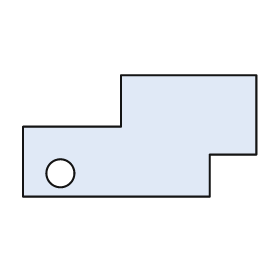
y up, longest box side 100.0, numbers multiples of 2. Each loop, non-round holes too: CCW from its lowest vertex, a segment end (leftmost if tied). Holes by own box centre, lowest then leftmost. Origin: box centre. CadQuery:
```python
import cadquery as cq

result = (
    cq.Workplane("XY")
    .moveTo(-50.0, -26.0)
    .lineTo(30.0, -26.0)
    .lineTo(30.0, -8.0)
    .lineTo(50.0, -8.0)
    .lineTo(50.0, 26.0)
    .lineTo(-8.0, 26.0)
    .lineTo(-8.0, 4.0)
    .lineTo(-50.0, 4.0)
    .close()
    .moveTo(-34.0, -16.0)
    .circle(6.0)
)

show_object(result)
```